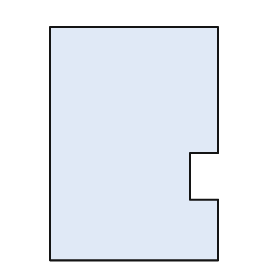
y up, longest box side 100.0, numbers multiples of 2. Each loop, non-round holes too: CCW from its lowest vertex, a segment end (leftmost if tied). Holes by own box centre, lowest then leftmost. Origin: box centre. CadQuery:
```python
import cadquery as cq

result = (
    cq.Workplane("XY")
    .moveTo(-36.0, -50.0)
    .lineTo(36.0, -50.0)
    .lineTo(36.0, -24.0)
    .lineTo(24.0, -24.0)
    .lineTo(24.0, -4.0)
    .lineTo(36.0, -4.0)
    .lineTo(36.0, 50.0)
    .lineTo(-36.0, 50.0)
    .close()
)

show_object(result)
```